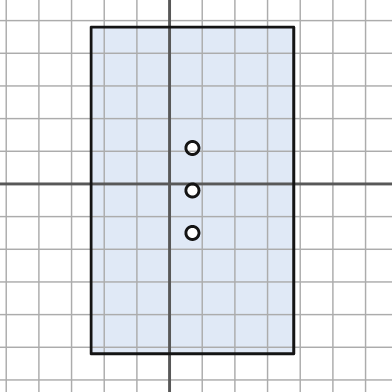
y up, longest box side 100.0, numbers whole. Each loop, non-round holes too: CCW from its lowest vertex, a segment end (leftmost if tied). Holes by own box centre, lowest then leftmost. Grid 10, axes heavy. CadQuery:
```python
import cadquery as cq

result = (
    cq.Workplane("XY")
    .moveTo(-24.0, -52.0)
    .lineTo(38.0, -52.0)
    .lineTo(38.0, 48.0)
    .lineTo(-24.0, 48.0)
    .close()
    .moveTo(7.0, -15.0)
    .circle(2.0)
    .moveTo(7.0, -2.0)
    .circle(2.0)
    .moveTo(7.0, 11.0)
    .circle(2.0)
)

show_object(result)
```